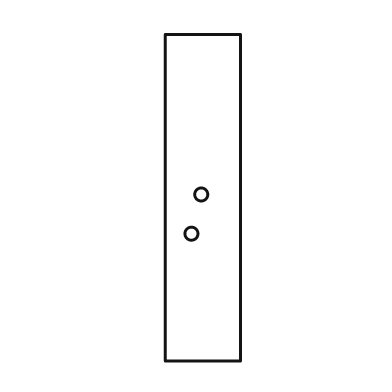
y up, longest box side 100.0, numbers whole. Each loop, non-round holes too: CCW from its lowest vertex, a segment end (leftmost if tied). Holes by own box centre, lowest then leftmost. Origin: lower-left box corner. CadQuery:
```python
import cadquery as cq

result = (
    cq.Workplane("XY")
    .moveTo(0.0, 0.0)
    .lineTo(23.0, 0.0)
    .lineTo(23.0, 100.0)
    .lineTo(0.0, 100.0)
    .close()
    .moveTo(8.0, 39.0)
    .circle(2.0)
    .moveTo(11.0, 51.0)
    .circle(2.0)
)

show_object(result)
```